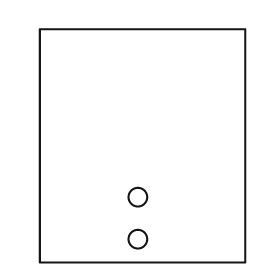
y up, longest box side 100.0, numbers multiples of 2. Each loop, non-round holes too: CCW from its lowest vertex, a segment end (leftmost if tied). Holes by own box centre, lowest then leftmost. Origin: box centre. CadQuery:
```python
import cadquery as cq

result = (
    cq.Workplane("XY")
    .moveTo(-44.0, -50.0)
    .lineTo(44.0, -50.0)
    .lineTo(44.0, 50.0)
    .lineTo(-44.0, 50.0)
    .close()
    .moveTo(-2.0, -40.0)
    .circle(4.0)
    .moveTo(-2.0, -22.0)
    .circle(4.0)
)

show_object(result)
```